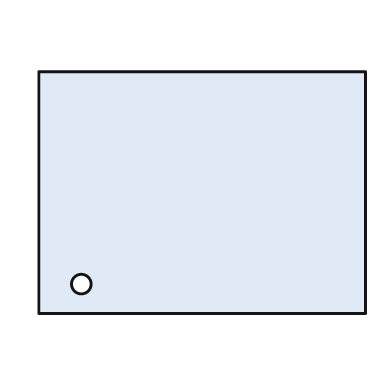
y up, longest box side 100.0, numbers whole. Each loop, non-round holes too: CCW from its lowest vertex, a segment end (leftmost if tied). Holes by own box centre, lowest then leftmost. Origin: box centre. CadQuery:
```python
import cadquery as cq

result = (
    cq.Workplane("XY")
    .moveTo(-50.0, -37.0)
    .lineTo(50.0, -37.0)
    .lineTo(50.0, 37.0)
    .lineTo(-50.0, 37.0)
    .close()
    .moveTo(-37.0, -28.0)
    .circle(3.0)
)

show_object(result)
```